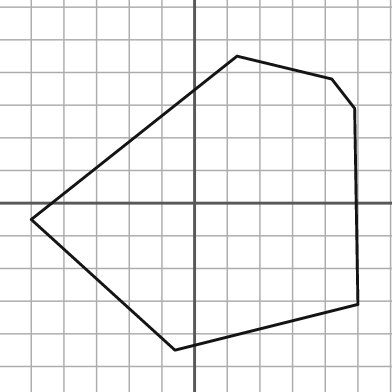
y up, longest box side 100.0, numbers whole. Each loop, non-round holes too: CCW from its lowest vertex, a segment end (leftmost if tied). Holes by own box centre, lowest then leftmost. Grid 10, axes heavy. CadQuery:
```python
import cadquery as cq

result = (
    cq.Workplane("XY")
    .moveTo(-6.0, -45.0)
    .lineTo(50.0, -31.0)
    .lineTo(49.0, 29.0)
    .lineTo(42.0, 38.0)
    .lineTo(13.0, 45.0)
    .lineTo(-50.0, -5.0)
    .close()
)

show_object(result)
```